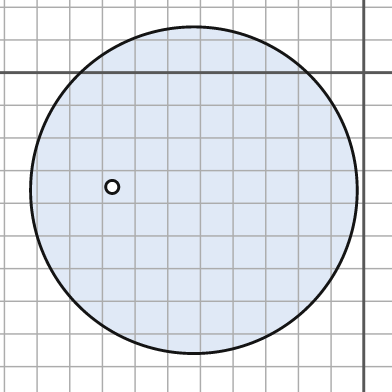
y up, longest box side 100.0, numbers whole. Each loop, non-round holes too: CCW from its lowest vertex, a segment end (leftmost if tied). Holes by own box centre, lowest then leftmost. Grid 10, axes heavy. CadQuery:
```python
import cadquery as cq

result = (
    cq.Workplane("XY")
    .moveTo(-52.0, -36.0)
    .circle(50.0)
    .moveTo(-77.0, -35.0)
    .circle(2.0)
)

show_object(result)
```